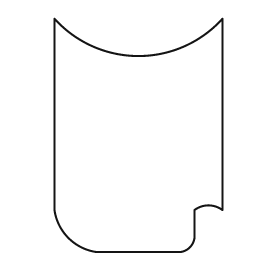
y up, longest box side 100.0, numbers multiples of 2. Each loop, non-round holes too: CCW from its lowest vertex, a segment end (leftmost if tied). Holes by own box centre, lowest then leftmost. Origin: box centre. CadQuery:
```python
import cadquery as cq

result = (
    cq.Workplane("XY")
    .moveTo(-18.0, -50.0)
    .lineTo(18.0, -50.0)
    .threePointArc((22.0, -48.0), (24.0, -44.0))
    .lineTo(24.0, -32.0)
    .threePointArc((30.0, -30.0), (36.0, -32.0))
    .lineTo(36.0, 50.0)
    .threePointArc((0.0, 34.0), (-36.0, 50.0))
    .lineTo(-36.0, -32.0)
    .threePointArc((-30.0, -44.0), (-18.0, -50.0))
    .close()
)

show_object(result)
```